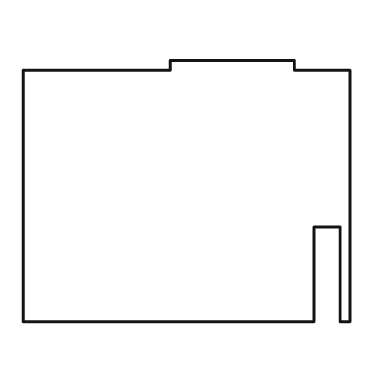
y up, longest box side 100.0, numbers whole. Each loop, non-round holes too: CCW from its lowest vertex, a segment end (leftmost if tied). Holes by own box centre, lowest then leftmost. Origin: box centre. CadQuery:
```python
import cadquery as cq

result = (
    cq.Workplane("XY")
    .moveTo(-50.0, -40.0)
    .lineTo(39.0, -40.0)
    .lineTo(39.0, -11.0)
    .lineTo(47.0, -11.0)
    .lineTo(47.0, -40.0)
    .lineTo(50.0, -40.0)
    .lineTo(50.0, 37.0)
    .lineTo(33.0, 37.0)
    .lineTo(33.0, 40.0)
    .lineTo(-5.0, 40.0)
    .lineTo(-5.0, 37.0)
    .lineTo(-50.0, 37.0)
    .close()
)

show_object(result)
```